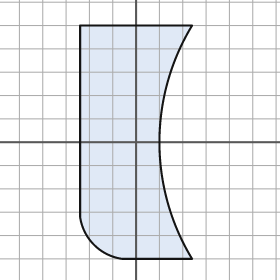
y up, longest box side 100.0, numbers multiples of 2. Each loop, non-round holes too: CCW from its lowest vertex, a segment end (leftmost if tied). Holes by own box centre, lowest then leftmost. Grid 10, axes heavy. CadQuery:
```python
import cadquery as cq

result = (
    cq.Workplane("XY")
    .moveTo(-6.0, -50.0)
    .lineTo(24.0, -50.0)
    .threePointArc((10.0, 0.0), (24.0, 50.0))
    .lineTo(-24.0, 50.0)
    .lineTo(-24.0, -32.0)
    .threePointArc((-18.0, -44.0), (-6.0, -50.0))
    .close()
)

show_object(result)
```